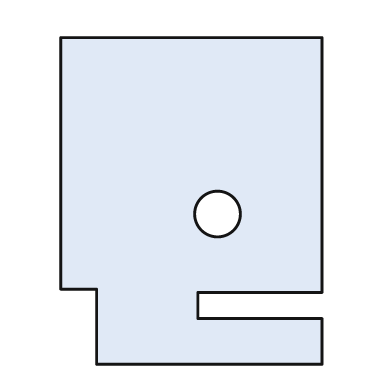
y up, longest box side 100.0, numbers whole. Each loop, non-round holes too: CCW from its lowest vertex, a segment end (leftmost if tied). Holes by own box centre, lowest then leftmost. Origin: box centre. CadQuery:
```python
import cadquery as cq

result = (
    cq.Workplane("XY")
    .moveTo(-29.0, -50.0)
    .lineTo(40.0, -50.0)
    .lineTo(40.0, -36.0)
    .lineTo(2.0, -36.0)
    .lineTo(2.0, -28.0)
    .lineTo(40.0, -28.0)
    .lineTo(40.0, 50.0)
    .lineTo(-40.0, 50.0)
    .lineTo(-40.0, -27.0)
    .lineTo(-29.0, -27.0)
    .close()
    .moveTo(8.0, -4.0)
    .circle(7.0)
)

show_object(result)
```